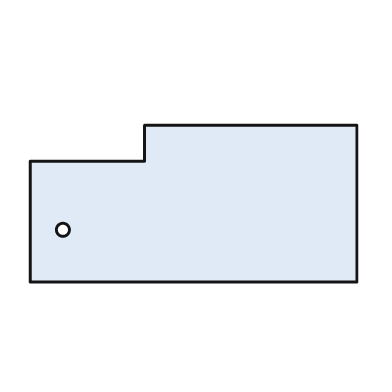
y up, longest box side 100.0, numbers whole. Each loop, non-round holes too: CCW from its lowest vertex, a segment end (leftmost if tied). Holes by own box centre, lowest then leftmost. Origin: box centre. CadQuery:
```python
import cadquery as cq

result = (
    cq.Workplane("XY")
    .moveTo(-50.0, -24.0)
    .lineTo(50.0, -24.0)
    .lineTo(50.0, 24.0)
    .lineTo(-15.0, 24.0)
    .lineTo(-15.0, 13.0)
    .lineTo(-50.0, 13.0)
    .close()
    .moveTo(-40.0, -8.0)
    .circle(2.0)
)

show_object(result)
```